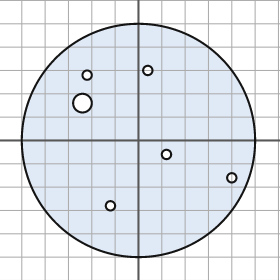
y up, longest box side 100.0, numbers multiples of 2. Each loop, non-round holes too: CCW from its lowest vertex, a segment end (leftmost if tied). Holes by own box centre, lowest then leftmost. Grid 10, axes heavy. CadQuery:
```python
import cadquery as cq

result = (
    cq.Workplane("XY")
    .moveTo(0.0, 0.0)
    .circle(50.0)
    .moveTo(-12.0, -28.0)
    .circle(2.0)
    .moveTo(40.0, -16.0)
    .circle(2.0)
    .moveTo(12.0, -6.0)
    .circle(2.0)
    .moveTo(-24.0, 16.0)
    .circle(4.0)
    .moveTo(-22.0, 28.0)
    .circle(2.0)
    .moveTo(4.0, 30.0)
    .circle(2.0)
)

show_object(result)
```